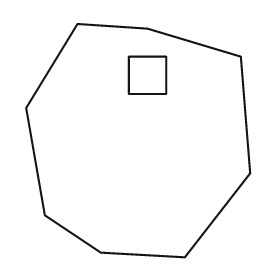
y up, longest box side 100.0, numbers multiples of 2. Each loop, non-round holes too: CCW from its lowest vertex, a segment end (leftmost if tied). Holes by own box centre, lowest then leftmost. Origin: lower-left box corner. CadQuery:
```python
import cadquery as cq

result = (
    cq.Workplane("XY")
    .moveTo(68.0, 0.0)
    .lineTo(96.0, 36.0)
    .lineTo(92.0, 86.0)
    .lineTo(52.0, 98.0)
    .lineTo(22.0, 100.0)
    .lineTo(0.0, 64.0)
    .lineTo(8.0, 18.0)
    .lineTo(32.0, 2.0)
    .close()
    .moveTo(44.0, 70.0)
    .lineTo(60.0, 70.0)
    .lineTo(60.0, 86.0)
    .lineTo(44.0, 86.0)
    .close()
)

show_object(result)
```